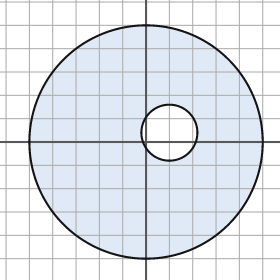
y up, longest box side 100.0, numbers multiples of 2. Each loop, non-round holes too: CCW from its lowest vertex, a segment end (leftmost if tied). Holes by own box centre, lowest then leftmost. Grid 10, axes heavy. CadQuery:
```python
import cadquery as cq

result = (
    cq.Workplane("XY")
    .moveTo(0.0, 0.0)
    .circle(50.0)
    .moveTo(10.0, 4.0)
    .circle(12.0)
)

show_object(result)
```